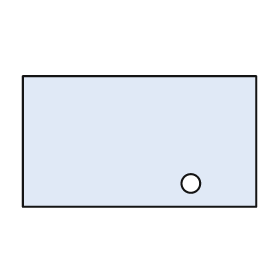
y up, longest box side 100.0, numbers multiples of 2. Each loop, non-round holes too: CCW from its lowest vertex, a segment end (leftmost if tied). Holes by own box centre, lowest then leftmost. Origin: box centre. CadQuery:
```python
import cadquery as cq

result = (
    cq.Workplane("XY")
    .moveTo(-50.0, -28.0)
    .lineTo(50.0, -28.0)
    .lineTo(50.0, 28.0)
    .lineTo(-50.0, 28.0)
    .close()
    .moveTo(22.0, -18.0)
    .circle(4.0)
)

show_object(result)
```